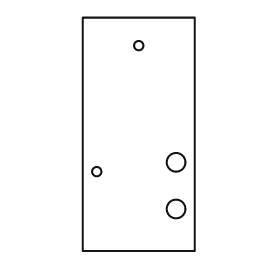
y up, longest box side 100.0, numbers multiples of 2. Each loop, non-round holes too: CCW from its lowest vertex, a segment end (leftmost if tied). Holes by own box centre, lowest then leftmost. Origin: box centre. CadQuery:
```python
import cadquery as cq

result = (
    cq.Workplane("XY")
    .moveTo(-24.0, -50.0)
    .lineTo(24.0, -50.0)
    .lineTo(24.0, 50.0)
    .lineTo(-24.0, 50.0)
    .close()
    .moveTo(16.0, -32.0)
    .circle(4.0)
    .moveTo(-18.0, -16.0)
    .circle(2.0)
    .moveTo(16.0, -12.0)
    .circle(4.0)
    .moveTo(0.0, 38.0)
    .circle(2.0)
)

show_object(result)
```